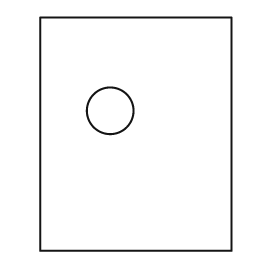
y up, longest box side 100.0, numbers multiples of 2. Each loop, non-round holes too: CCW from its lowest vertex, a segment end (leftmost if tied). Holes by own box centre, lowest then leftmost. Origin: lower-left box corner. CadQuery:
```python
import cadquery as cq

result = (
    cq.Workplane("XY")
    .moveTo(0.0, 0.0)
    .lineTo(82.0, 0.0)
    .lineTo(82.0, 100.0)
    .lineTo(0.0, 100.0)
    .close()
    .moveTo(30.0, 60.0)
    .circle(10.0)
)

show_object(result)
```